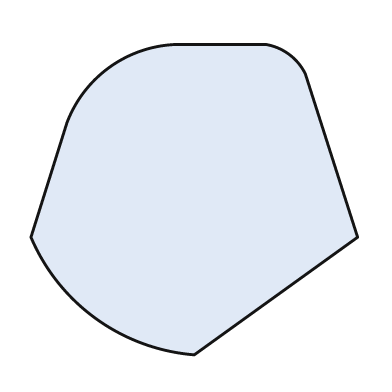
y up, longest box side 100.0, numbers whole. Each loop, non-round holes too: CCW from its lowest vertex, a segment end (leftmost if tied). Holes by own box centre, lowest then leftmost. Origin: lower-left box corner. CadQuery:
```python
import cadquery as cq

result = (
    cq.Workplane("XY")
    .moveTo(50.0, 0.0)
    .lineTo(100.0, 36.0)
    .lineTo(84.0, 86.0)
    .threePointArc((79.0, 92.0), (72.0, 95.0))
    .lineTo(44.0, 95.0)
    .threePointArc((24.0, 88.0), (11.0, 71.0))
    .lineTo(0.0, 36.0)
    .threePointArc((20.0, 11.0), (50.0, 0.0))
    .close()
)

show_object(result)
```